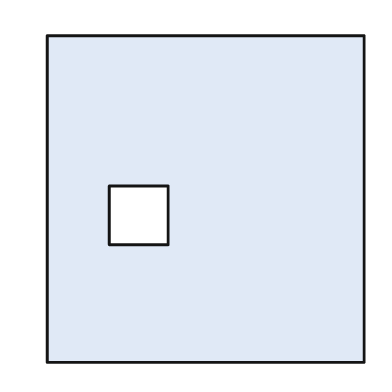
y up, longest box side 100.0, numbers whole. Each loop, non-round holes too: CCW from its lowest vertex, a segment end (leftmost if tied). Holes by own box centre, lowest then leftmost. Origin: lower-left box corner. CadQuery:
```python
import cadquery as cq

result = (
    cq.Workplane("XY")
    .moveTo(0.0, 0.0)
    .lineTo(97.0, 0.0)
    .lineTo(97.0, 100.0)
    .lineTo(0.0, 100.0)
    .close()
    .moveTo(19.0, 36.0)
    .lineTo(37.0, 36.0)
    .lineTo(37.0, 54.0)
    .lineTo(19.0, 54.0)
    .close()
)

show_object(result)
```